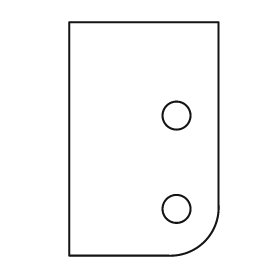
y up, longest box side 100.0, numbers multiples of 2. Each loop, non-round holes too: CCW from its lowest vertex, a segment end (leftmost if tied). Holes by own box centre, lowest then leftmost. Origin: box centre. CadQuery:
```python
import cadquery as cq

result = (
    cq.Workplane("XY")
    .moveTo(-32.0, -50.0)
    .lineTo(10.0, -50.0)
    .threePointArc((26.0, -44.0), (32.0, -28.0))
    .lineTo(32.0, 50.0)
    .lineTo(-32.0, 50.0)
    .close()
    .moveTo(14.0, -30.0)
    .circle(6.0)
    .moveTo(14.0, 10.0)
    .circle(6.0)
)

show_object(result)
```